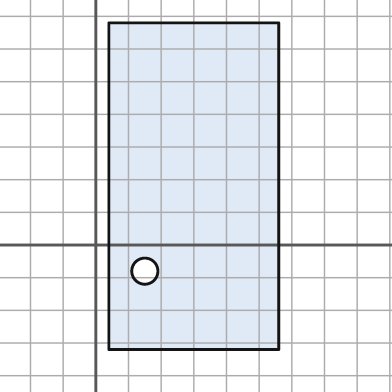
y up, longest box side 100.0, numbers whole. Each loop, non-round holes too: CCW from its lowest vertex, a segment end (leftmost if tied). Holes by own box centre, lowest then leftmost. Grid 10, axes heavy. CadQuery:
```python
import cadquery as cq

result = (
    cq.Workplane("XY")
    .moveTo(4.0, -32.0)
    .lineTo(56.0, -32.0)
    .lineTo(56.0, 68.0)
    .lineTo(4.0, 68.0)
    .close()
    .moveTo(15.0, -8.0)
    .circle(4.0)
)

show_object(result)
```